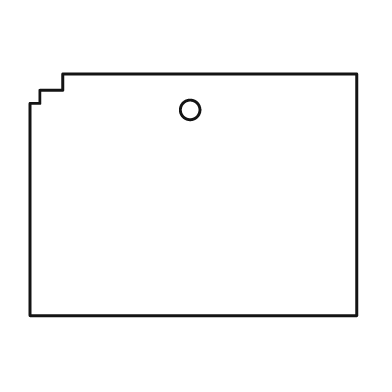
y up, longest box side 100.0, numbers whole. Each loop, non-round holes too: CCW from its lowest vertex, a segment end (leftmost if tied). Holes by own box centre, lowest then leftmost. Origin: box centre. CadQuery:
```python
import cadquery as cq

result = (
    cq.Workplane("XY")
    .moveTo(-50.0, -37.0)
    .lineTo(50.0, -37.0)
    .lineTo(50.0, 37.0)
    .lineTo(-40.0, 37.0)
    .lineTo(-40.0, 32.0)
    .lineTo(-47.0, 32.0)
    .lineTo(-47.0, 28.0)
    .lineTo(-50.0, 28.0)
    .close()
    .moveTo(-1.0, 26.0)
    .circle(3.0)
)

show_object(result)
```